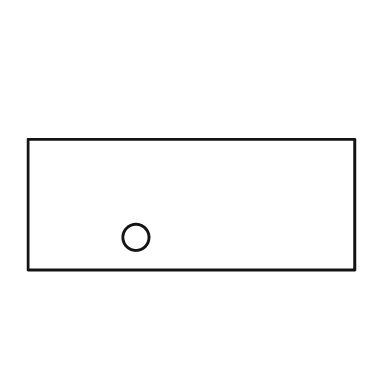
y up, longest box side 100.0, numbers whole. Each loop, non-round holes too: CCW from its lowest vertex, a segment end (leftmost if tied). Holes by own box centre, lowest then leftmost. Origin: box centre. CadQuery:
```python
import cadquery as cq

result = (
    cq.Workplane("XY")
    .moveTo(-50.0, -20.0)
    .lineTo(50.0, -20.0)
    .lineTo(50.0, 20.0)
    .lineTo(-50.0, 20.0)
    .close()
    .moveTo(-17.0, -10.0)
    .circle(4.0)
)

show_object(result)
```